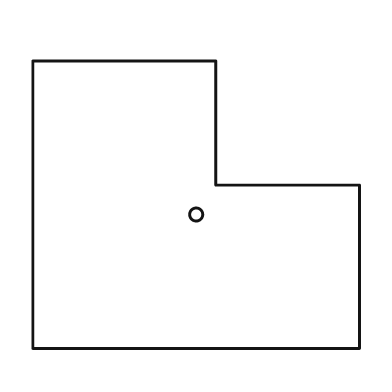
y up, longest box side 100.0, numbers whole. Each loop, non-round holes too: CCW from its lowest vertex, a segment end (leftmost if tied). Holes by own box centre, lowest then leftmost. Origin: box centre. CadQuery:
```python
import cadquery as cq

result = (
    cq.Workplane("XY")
    .moveTo(-50.0, -44.0)
    .lineTo(50.0, -44.0)
    .lineTo(50.0, 6.0)
    .lineTo(6.0, 6.0)
    .lineTo(6.0, 44.0)
    .lineTo(-50.0, 44.0)
    .close()
    .moveTo(0.0, -3.0)
    .circle(2.0)
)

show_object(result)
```